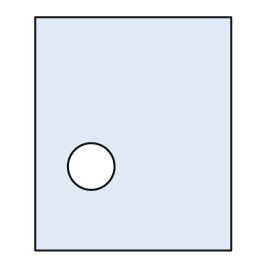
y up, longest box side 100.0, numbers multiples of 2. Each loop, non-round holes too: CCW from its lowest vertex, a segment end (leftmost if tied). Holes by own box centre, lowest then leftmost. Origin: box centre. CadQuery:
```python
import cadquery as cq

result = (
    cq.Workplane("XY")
    .moveTo(-42.0, -50.0)
    .lineTo(42.0, -50.0)
    .lineTo(42.0, 50.0)
    .lineTo(-42.0, 50.0)
    .close()
    .moveTo(-18.0, -14.0)
    .circle(10.0)
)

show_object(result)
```